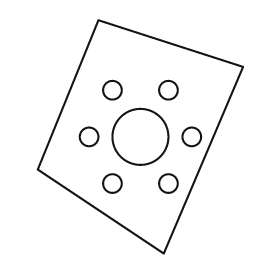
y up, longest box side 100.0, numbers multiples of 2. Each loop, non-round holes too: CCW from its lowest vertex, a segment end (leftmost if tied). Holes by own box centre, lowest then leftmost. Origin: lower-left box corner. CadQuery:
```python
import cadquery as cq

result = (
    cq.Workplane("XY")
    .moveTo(54.0, 0.0)
    .lineTo(88.0, 80.0)
    .lineTo(26.0, 100.0)
    .lineTo(0.0, 36.0)
    .close()
    .moveTo(32.0, 30.0)
    .circle(4.0)
    .moveTo(56.0, 30.0)
    .circle(4.0)
    .moveTo(22.0, 50.0)
    .circle(4.0)
    .moveTo(44.0, 50.0)
    .circle(12.0)
    .moveTo(66.0, 50.0)
    .circle(4.0)
    .moveTo(32.0, 70.0)
    .circle(4.0)
    .moveTo(56.0, 70.0)
    .circle(4.0)
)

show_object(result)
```